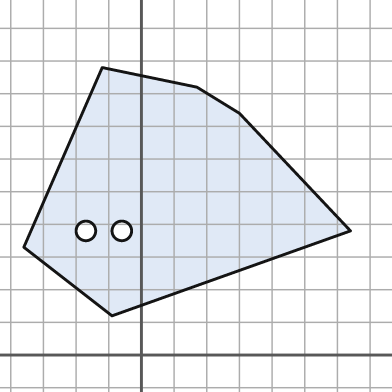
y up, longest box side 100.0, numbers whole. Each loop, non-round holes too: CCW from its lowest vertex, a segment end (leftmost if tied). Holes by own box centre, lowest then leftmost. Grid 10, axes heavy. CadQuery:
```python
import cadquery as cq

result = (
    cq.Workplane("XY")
    .moveTo(-9.0, 12.0)
    .lineTo(64.0, 38.0)
    .lineTo(30.0, 74.0)
    .lineTo(17.0, 82.0)
    .lineTo(-12.0, 88.0)
    .lineTo(-36.0, 33.0)
    .close()
    .moveTo(-17.0, 38.0)
    .circle(3.0)
    .moveTo(-6.0, 38.0)
    .circle(3.0)
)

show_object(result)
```